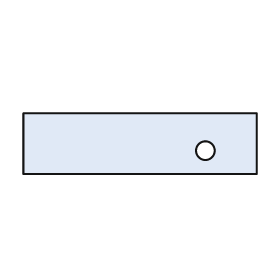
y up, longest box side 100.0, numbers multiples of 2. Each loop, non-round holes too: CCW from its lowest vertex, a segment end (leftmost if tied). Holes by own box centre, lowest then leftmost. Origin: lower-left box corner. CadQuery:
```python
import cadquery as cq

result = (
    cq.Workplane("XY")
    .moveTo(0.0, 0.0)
    .lineTo(100.0, 0.0)
    .lineTo(100.0, 26.0)
    .lineTo(0.0, 26.0)
    .close()
    .moveTo(78.0, 10.0)
    .circle(4.0)
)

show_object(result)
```